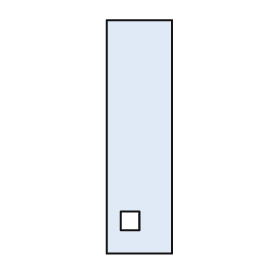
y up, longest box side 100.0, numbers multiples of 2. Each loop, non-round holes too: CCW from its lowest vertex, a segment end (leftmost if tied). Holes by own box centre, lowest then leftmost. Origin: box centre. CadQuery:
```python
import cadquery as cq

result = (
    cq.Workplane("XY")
    .moveTo(-14.0, -50.0)
    .lineTo(14.0, -50.0)
    .lineTo(14.0, 50.0)
    .lineTo(-14.0, 50.0)
    .close()
    .moveTo(-8.0, -40.0)
    .lineTo(0.0, -40.0)
    .lineTo(0.0, -32.0)
    .lineTo(-8.0, -32.0)
    .close()
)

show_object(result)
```